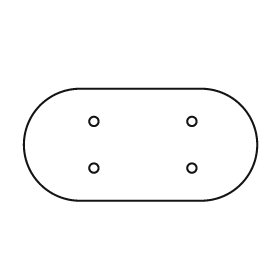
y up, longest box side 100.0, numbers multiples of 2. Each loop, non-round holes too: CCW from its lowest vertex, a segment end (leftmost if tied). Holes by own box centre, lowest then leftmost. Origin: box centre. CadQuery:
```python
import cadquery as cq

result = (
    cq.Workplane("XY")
    .moveTo(-26.0, -24.0)
    .lineTo(26.0, -24.0)
    .threePointArc((50.0, 0.0), (26.0, 24.0))
    .lineTo(-26.0, 24.0)
    .threePointArc((-50.0, 0.0), (-26.0, -24.0))
    .close()
    .moveTo(-20.0, -10.0)
    .circle(2.0)
    .moveTo(22.0, -10.0)
    .circle(2.0)
    .moveTo(-20.0, 10.0)
    .circle(2.0)
    .moveTo(22.0, 10.0)
    .circle(2.0)
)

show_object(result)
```